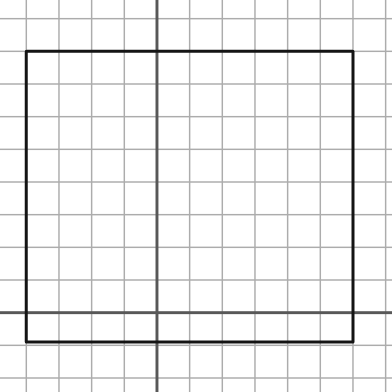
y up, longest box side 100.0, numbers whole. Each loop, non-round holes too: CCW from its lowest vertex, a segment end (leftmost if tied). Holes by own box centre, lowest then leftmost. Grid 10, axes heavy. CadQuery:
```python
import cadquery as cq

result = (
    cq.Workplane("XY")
    .moveTo(-40.0, -9.0)
    .lineTo(60.0, -9.0)
    .lineTo(60.0, 80.0)
    .lineTo(-40.0, 80.0)
    .close()
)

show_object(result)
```